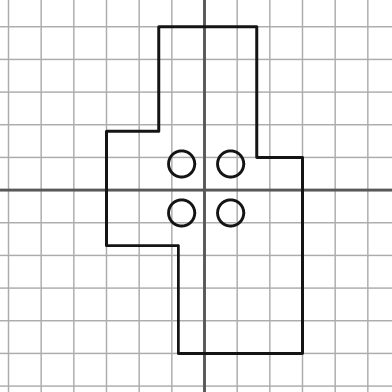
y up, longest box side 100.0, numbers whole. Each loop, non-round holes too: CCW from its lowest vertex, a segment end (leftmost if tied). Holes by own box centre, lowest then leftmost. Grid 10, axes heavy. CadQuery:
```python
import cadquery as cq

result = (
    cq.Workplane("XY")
    .moveTo(-8.0, -50.0)
    .lineTo(30.0, -50.0)
    .lineTo(30.0, 10.0)
    .lineTo(16.0, 10.0)
    .lineTo(16.0, 50.0)
    .lineTo(-14.0, 50.0)
    .lineTo(-14.0, 18.0)
    .lineTo(-30.0, 18.0)
    .lineTo(-30.0, -17.0)
    .lineTo(-8.0, -17.0)
    .close()
    .moveTo(-7.0, -7.0)
    .circle(4.0)
    .moveTo(8.0, -7.0)
    .circle(4.0)
    .moveTo(-7.0, 8.0)
    .circle(4.0)
    .moveTo(8.0, 8.0)
    .circle(4.0)
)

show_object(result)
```